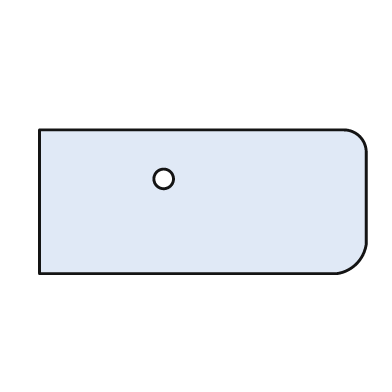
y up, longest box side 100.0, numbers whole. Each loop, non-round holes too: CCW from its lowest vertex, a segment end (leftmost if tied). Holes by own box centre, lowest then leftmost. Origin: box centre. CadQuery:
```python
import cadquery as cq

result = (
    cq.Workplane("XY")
    .moveTo(-50.0, -22.0)
    .lineTo(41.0, -22.0)
    .threePointArc((47.0, -19.0), (50.0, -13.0))
    .lineTo(50.0, 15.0)
    .threePointArc((48.0, 20.0), (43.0, 22.0))
    .lineTo(-50.0, 22.0)
    .close()
    .moveTo(-12.0, 7.0)
    .circle(3.0)
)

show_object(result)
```